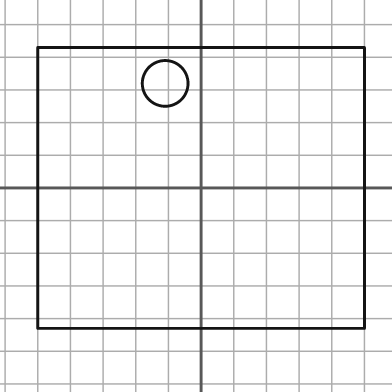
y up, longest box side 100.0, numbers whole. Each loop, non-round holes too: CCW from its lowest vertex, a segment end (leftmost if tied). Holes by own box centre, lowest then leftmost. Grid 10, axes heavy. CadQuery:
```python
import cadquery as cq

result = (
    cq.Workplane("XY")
    .moveTo(-50.0, -43.0)
    .lineTo(50.0, -43.0)
    .lineTo(50.0, 43.0)
    .lineTo(-50.0, 43.0)
    .close()
    .moveTo(-11.0, 32.0)
    .circle(7.0)
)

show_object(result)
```